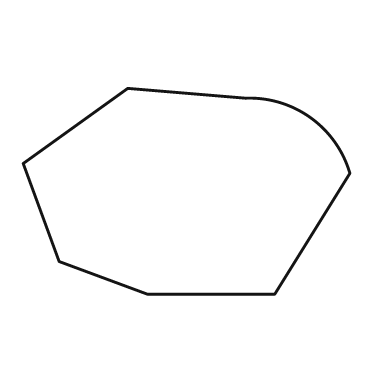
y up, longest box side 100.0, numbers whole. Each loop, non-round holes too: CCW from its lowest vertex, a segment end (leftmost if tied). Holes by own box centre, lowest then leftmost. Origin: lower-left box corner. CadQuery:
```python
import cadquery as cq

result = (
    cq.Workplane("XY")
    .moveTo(38.0, 0.0)
    .lineTo(77.0, 0.0)
    .lineTo(100.0, 37.0)
    .threePointArc((88.0, 54.0), (68.0, 60.0))
    .lineTo(32.0, 63.0)
    .lineTo(0.0, 40.0)
    .lineTo(11.0, 10.0)
    .close()
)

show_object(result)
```